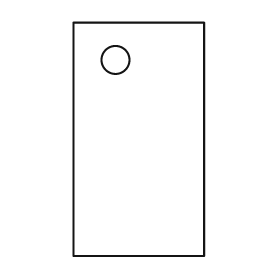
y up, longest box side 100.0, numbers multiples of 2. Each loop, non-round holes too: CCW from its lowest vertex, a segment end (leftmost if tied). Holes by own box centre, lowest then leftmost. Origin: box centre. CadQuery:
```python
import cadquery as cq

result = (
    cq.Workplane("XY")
    .moveTo(-28.0, -50.0)
    .lineTo(28.0, -50.0)
    .lineTo(28.0, 50.0)
    .lineTo(-28.0, 50.0)
    .close()
    .moveTo(-10.0, 34.0)
    .circle(6.0)
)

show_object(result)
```